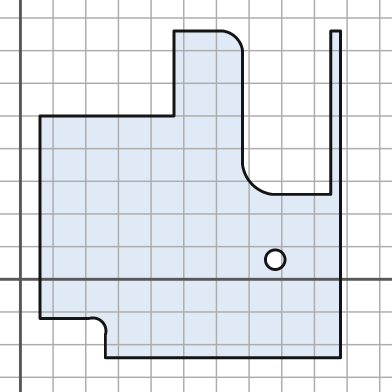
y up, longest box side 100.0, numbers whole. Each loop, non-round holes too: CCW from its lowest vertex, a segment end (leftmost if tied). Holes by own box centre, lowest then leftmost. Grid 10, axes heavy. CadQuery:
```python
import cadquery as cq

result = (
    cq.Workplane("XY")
    .moveTo(26.0, -24.0)
    .lineTo(98.0, -24.0)
    .lineTo(98.0, 76.0)
    .lineTo(95.0, 76.0)
    .lineTo(95.0, 26.0)
    .lineTo(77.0, 26.0)
    .threePointArc((71.0, 29.0), (68.0, 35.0))
    .lineTo(68.0, 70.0)
    .threePointArc((66.0, 74.0), (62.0, 76.0))
    .lineTo(47.0, 76.0)
    .lineTo(47.0, 50.0)
    .lineTo(6.0, 50.0)
    .lineTo(6.0, -12.0)
    .lineTo(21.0, -12.0)
    .threePointArc((25.0, -13.0), (26.0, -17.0))
    .close()
    .moveTo(78.0, 6.0)
    .circle(3.0)
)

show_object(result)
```